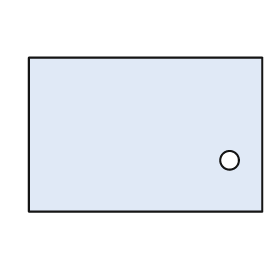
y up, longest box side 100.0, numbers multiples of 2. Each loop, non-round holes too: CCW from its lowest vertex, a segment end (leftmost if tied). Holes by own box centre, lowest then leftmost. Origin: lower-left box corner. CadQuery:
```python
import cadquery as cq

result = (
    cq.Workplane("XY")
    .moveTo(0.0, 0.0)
    .lineTo(100.0, 0.0)
    .lineTo(100.0, 66.0)
    .lineTo(0.0, 66.0)
    .close()
    .moveTo(86.0, 22.0)
    .circle(4.0)
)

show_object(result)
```